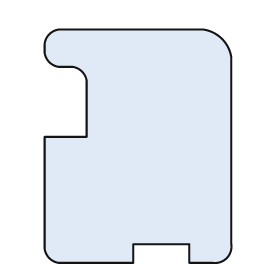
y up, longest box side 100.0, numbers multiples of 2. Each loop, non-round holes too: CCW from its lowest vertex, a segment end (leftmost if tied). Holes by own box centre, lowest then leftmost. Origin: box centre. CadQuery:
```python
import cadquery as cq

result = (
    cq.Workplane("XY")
    .moveTo(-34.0, -50.0)
    .lineTo(-2.0, -50.0)
    .lineTo(-2.0, -42.0)
    .lineTo(22.0, -42.0)
    .lineTo(22.0, -50.0)
    .lineTo(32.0, -50.0)
    .threePointArc((38.0, -48.0), (40.0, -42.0))
    .lineTo(40.0, 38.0)
    .threePointArc((36.0, 46.0), (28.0, 50.0))
    .lineTo(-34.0, 50.0)
    .threePointArc((-38.0, 48.0), (-40.0, 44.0))
    .lineTo(-40.0, 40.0)
    .threePointArc((-38.0, 36.0), (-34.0, 34.0))
    .lineTo(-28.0, 34.0)
    .threePointArc((-24.0, 32.0), (-22.0, 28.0))
    .lineTo(-22.0, 4.0)
    .lineTo(-40.0, 4.0)
    .lineTo(-40.0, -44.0)
    .threePointArc((-38.0, -48.0), (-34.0, -50.0))
    .close()
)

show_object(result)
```